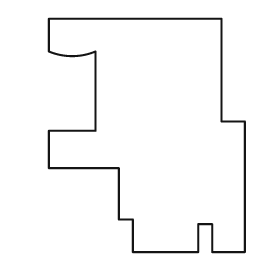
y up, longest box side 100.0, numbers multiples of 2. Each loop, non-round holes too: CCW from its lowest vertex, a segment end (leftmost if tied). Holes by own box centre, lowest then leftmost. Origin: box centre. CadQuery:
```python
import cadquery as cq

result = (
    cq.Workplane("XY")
    .moveTo(-6.0, -50.0)
    .lineTo(22.0, -50.0)
    .lineTo(22.0, -38.0)
    .lineTo(28.0, -38.0)
    .lineTo(28.0, -50.0)
    .lineTo(42.0, -50.0)
    .lineTo(42.0, 6.0)
    .lineTo(32.0, 6.0)
    .lineTo(32.0, 50.0)
    .lineTo(-42.0, 50.0)
    .lineTo(-42.0, 36.0)
    .threePointArc((-32.0, 34.0), (-22.0, 36.0))
    .lineTo(-22.0, 2.0)
    .lineTo(-42.0, 2.0)
    .lineTo(-42.0, -14.0)
    .lineTo(-12.0, -14.0)
    .lineTo(-12.0, -36.0)
    .lineTo(-6.0, -36.0)
    .close()
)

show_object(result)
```